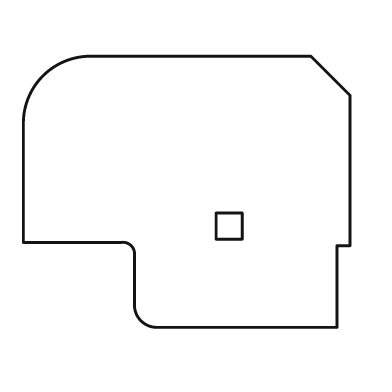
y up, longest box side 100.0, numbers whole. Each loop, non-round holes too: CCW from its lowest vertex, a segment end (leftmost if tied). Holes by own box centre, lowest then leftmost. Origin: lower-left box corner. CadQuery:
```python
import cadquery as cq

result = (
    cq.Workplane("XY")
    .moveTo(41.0, 0.0)
    .lineTo(96.0, 0.0)
    .lineTo(96.0, 25.0)
    .lineTo(100.0, 25.0)
    .lineTo(100.0, 71.0)
    .lineTo(88.0, 83.0)
    .lineTo(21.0, 83.0)
    .threePointArc((6.0, 77.0), (0.0, 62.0))
    .lineTo(0.0, 26.0)
    .lineTo(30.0, 26.0)
    .threePointArc((33.0, 25.0), (34.0, 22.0))
    .lineTo(34.0, 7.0)
    .threePointArc((36.0, 2.0), (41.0, 0.0))
    .close()
    .moveTo(59.0, 27.0)
    .lineTo(67.0, 27.0)
    .lineTo(67.0, 35.0)
    .lineTo(59.0, 35.0)
    .close()
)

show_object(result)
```